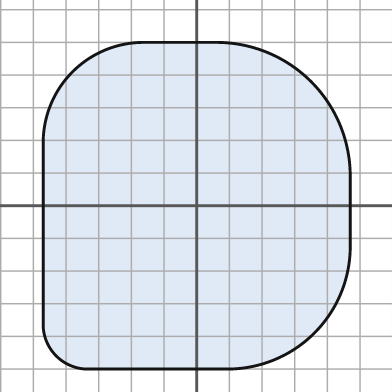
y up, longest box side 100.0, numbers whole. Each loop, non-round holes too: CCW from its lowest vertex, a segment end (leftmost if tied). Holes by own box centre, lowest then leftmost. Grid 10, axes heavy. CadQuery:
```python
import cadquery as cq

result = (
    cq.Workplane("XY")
    .moveTo(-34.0, -50.0)
    .lineTo(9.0, -50.0)
    .threePointArc((36.0, -39.0), (47.0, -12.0))
    .lineTo(47.0, 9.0)
    .threePointArc((35.0, 38.0), (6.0, 50.0))
    .lineTo(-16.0, 50.0)
    .threePointArc((-38.0, 41.0), (-47.0, 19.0))
    .lineTo(-47.0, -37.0)
    .threePointArc((-43.0, -46.0), (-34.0, -50.0))
    .close()
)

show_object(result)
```